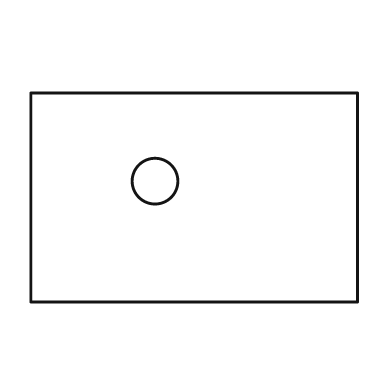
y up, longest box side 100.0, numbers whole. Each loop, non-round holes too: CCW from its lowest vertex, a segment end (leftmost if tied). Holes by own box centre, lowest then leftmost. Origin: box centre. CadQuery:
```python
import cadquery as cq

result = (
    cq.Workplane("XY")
    .moveTo(-50.0, -32.0)
    .lineTo(50.0, -32.0)
    .lineTo(50.0, 32.0)
    .lineTo(-50.0, 32.0)
    .close()
    .moveTo(-12.0, 5.0)
    .circle(7.0)
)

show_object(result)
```